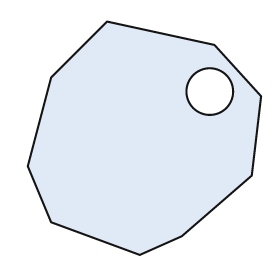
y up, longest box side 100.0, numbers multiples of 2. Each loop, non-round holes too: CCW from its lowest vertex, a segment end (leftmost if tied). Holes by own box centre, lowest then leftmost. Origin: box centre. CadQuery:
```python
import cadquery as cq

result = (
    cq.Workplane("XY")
    .moveTo(-2.0, -50.0)
    .lineTo(16.0, -42.0)
    .lineTo(46.0, -16.0)
    .lineTo(50.0, 18.0)
    .lineTo(30.0, 40.0)
    .lineTo(-16.0, 50.0)
    .lineTo(-40.0, 26.0)
    .lineTo(-50.0, -12.0)
    .lineTo(-40.0, -36.0)
    .close()
    .moveTo(28.0, 20.0)
    .circle(10.0)
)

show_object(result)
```